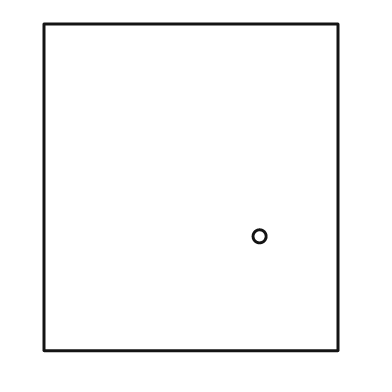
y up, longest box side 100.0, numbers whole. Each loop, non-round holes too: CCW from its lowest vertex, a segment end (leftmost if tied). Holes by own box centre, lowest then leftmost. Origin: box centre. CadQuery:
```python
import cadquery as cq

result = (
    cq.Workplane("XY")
    .moveTo(-45.0, -50.0)
    .lineTo(45.0, -50.0)
    .lineTo(45.0, 50.0)
    .lineTo(-45.0, 50.0)
    .close()
    .moveTo(21.0, -15.0)
    .circle(2.0)
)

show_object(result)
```